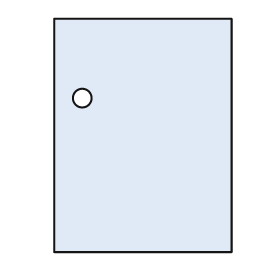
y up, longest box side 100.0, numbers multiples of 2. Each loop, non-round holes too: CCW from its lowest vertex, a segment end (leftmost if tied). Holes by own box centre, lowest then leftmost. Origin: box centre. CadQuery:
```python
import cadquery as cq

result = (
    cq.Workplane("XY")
    .moveTo(-38.0, -50.0)
    .lineTo(38.0, -50.0)
    .lineTo(38.0, 50.0)
    .lineTo(-38.0, 50.0)
    .close()
    .moveTo(-26.0, 16.0)
    .circle(4.0)
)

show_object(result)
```